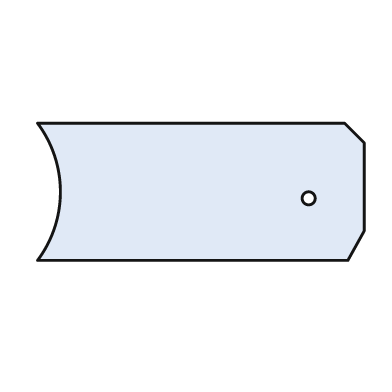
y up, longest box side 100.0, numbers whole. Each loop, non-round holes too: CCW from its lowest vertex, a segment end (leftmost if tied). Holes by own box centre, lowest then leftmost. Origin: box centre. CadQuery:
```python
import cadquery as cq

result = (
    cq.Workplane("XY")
    .moveTo(-50.0, -21.0)
    .lineTo(45.0, -21.0)
    .lineTo(50.0, -12.0)
    .lineTo(50.0, 15.0)
    .lineTo(44.0, 21.0)
    .lineTo(-50.0, 21.0)
    .threePointArc((-43.0, 0.0), (-50.0, -21.0))
    .close()
    .moveTo(33.0, -2.0)
    .circle(2.0)
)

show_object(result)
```